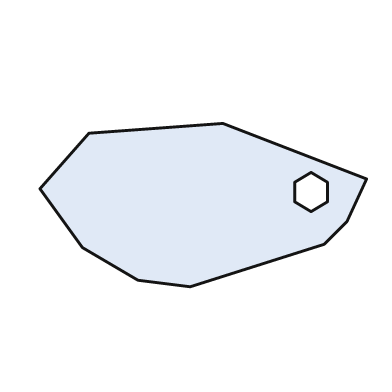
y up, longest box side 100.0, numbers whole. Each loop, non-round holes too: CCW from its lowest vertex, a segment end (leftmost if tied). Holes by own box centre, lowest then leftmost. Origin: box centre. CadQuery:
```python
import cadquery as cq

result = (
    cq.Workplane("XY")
    .moveTo(-4.0, -25.0)
    .lineTo(37.0, -12.0)
    .lineTo(44.0, -5.0)
    .lineTo(50.0, 8.0)
    .lineTo(6.0, 25.0)
    .lineTo(-35.0, 22.0)
    .lineTo(-50.0, 5.0)
    .lineTo(-37.0, -13.0)
    .lineTo(-20.0, -23.0)
    .close()
    .moveTo(33.0, -2.0)
    .lineTo(38.0, 1.0)
    .lineTo(38.0, 7.0)
    .lineTo(33.0, 10.0)
    .lineTo(28.0, 7.0)
    .lineTo(28.0, 1.0)
    .close()
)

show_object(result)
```